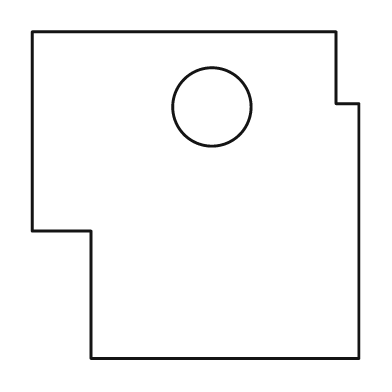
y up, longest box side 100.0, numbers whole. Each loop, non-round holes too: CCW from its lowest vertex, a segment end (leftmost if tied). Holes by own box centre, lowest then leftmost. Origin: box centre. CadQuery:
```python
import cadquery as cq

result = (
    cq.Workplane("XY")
    .moveTo(-32.0, -50.0)
    .lineTo(50.0, -50.0)
    .lineTo(50.0, 28.0)
    .lineTo(43.0, 28.0)
    .lineTo(43.0, 50.0)
    .lineTo(-50.0, 50.0)
    .lineTo(-50.0, -11.0)
    .lineTo(-32.0, -11.0)
    .close()
    .moveTo(5.0, 27.0)
    .circle(12.0)
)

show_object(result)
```